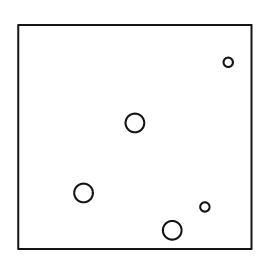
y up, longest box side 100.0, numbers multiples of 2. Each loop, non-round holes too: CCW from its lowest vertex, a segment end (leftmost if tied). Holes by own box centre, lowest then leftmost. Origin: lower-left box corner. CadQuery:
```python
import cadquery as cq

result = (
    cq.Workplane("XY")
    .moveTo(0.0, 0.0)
    .lineTo(100.0, 0.0)
    .lineTo(100.0, 96.0)
    .lineTo(0.0, 96.0)
    .close()
    .moveTo(66.0, 8.0)
    .circle(4.0)
    .moveTo(80.0, 18.0)
    .circle(2.0)
    .moveTo(28.0, 24.0)
    .circle(4.0)
    .moveTo(50.0, 54.0)
    .circle(4.0)
    .moveTo(90.0, 80.0)
    .circle(2.0)
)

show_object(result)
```